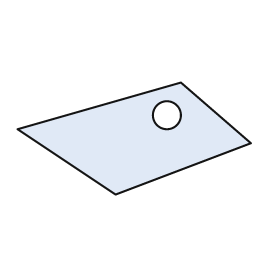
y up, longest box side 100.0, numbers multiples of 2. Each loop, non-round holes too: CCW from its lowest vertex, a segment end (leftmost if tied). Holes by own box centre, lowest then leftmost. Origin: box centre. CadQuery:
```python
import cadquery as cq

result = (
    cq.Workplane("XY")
    .moveTo(-8.0, -24.0)
    .lineTo(50.0, -2.0)
    .lineTo(20.0, 24.0)
    .lineTo(-50.0, 4.0)
    .close()
    .moveTo(14.0, 10.0)
    .circle(6.0)
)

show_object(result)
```